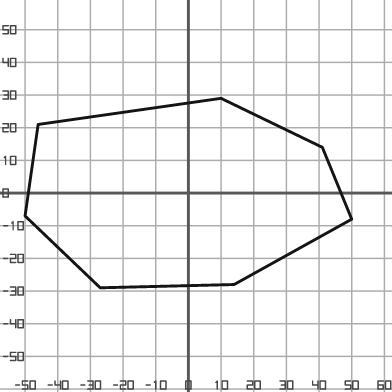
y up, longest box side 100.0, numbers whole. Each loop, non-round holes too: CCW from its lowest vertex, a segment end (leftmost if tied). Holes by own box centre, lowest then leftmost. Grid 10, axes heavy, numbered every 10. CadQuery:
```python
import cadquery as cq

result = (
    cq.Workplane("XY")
    .moveTo(-27.0, -29.0)
    .lineTo(14.0, -28.0)
    .lineTo(50.0, -8.0)
    .lineTo(41.0, 14.0)
    .lineTo(10.0, 29.0)
    .lineTo(-46.0, 21.0)
    .lineTo(-50.0, -7.0)
    .close()
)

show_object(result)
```